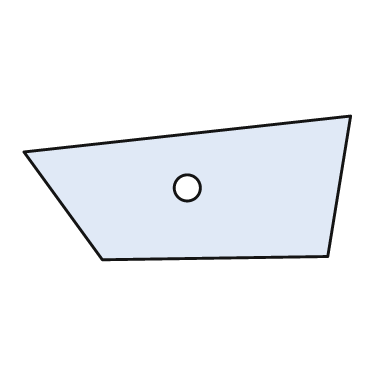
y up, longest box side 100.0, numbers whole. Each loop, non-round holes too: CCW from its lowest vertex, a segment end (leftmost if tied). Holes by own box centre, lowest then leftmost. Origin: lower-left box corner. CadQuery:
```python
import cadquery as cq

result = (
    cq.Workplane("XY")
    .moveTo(24.0, 0.0)
    .lineTo(93.0, 1.0)
    .lineTo(100.0, 44.0)
    .lineTo(0.0, 33.0)
    .close()
    .moveTo(50.0, 22.0)
    .circle(4.0)
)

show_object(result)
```